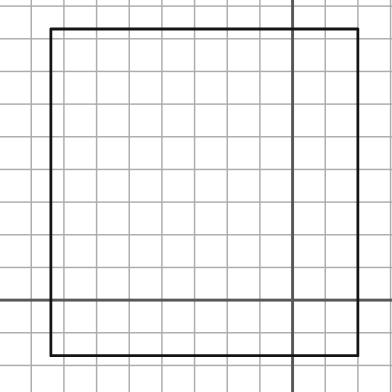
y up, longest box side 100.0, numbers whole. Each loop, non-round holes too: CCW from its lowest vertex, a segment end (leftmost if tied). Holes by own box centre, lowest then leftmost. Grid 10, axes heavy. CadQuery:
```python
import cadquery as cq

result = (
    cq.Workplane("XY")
    .moveTo(-74.0, -17.0)
    .lineTo(20.0, -17.0)
    .lineTo(20.0, 83.0)
    .lineTo(-74.0, 83.0)
    .close()
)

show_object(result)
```